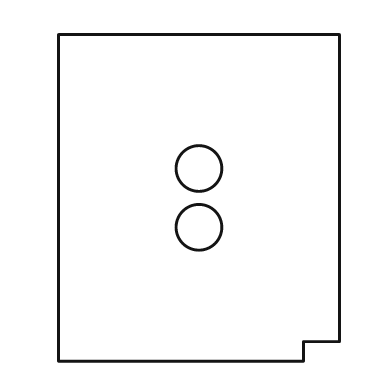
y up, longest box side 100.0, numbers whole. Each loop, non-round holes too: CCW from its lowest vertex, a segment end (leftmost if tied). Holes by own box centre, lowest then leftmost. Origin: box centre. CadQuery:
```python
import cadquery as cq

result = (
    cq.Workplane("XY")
    .moveTo(-43.0, -50.0)
    .lineTo(32.0, -50.0)
    .lineTo(32.0, -44.0)
    .lineTo(43.0, -44.0)
    .lineTo(43.0, 50.0)
    .lineTo(-43.0, 50.0)
    .close()
    .moveTo(0.0, -9.0)
    .circle(7.0)
    .moveTo(0.0, 9.0)
    .circle(7.0)
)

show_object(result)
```